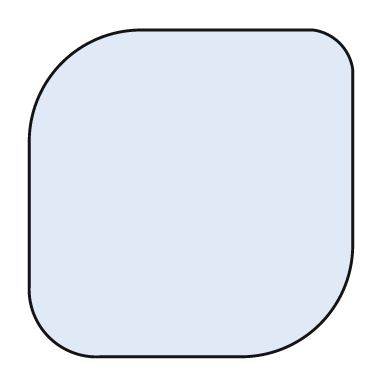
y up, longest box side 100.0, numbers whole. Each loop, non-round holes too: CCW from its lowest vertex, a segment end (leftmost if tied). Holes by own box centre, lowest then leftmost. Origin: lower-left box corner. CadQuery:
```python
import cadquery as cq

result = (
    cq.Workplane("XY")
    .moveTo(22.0, 0.0)
    .lineTo(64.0, 0.0)
    .threePointArc((89.0, 10.0), (99.0, 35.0))
    .lineTo(99.0, 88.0)
    .threePointArc((95.0, 96.0), (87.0, 100.0))
    .lineTo(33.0, 100.0)
    .threePointArc((10.0, 90.0), (0.0, 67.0))
    .lineTo(0.0, 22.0)
    .threePointArc((6.0, 6.0), (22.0, 0.0))
    .close()
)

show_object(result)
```